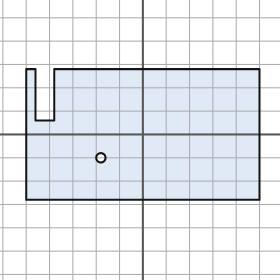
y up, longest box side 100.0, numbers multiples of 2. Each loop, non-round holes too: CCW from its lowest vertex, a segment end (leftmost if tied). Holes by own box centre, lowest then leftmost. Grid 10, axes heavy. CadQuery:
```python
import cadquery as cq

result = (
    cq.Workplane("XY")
    .moveTo(-50.0, -28.0)
    .lineTo(50.0, -28.0)
    .lineTo(50.0, 28.0)
    .lineTo(-38.0, 28.0)
    .lineTo(-38.0, 6.0)
    .lineTo(-46.0, 6.0)
    .lineTo(-46.0, 28.0)
    .lineTo(-50.0, 28.0)
    .close()
    .moveTo(-18.0, -10.0)
    .circle(2.0)
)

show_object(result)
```